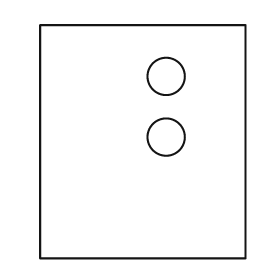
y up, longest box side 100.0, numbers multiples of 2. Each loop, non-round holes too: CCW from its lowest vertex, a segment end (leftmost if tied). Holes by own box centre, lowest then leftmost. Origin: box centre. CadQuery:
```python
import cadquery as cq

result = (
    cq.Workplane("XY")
    .moveTo(-44.0, -50.0)
    .lineTo(44.0, -50.0)
    .lineTo(44.0, 50.0)
    .lineTo(-44.0, 50.0)
    .close()
    .moveTo(10.0, 2.0)
    .circle(8.0)
    .moveTo(10.0, 28.0)
    .circle(8.0)
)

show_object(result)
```